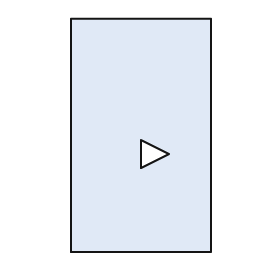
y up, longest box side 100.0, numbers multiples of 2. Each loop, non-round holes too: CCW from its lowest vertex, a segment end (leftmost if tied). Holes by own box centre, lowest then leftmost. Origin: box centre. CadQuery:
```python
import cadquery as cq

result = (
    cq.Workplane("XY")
    .moveTo(-30.0, -50.0)
    .lineTo(30.0, -50.0)
    .lineTo(30.0, 50.0)
    .lineTo(-30.0, 50.0)
    .close()
    .moveTo(0.0, -14.0)
    .lineTo(12.0, -8.0)
    .lineTo(0.0, -2.0)
    .close()
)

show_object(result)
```